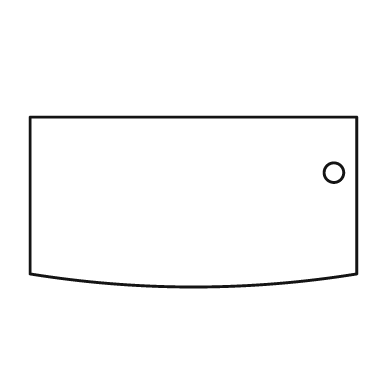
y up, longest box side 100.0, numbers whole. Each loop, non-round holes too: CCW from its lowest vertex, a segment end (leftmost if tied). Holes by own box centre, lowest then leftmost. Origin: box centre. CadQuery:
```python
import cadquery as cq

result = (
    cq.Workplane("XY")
    .moveTo(-50.0, -22.0)
    .threePointArc((0.0, -26.0), (50.0, -22.0))
    .lineTo(50.0, 26.0)
    .lineTo(-50.0, 26.0)
    .close()
    .moveTo(43.0, 9.0)
    .circle(3.0)
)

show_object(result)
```